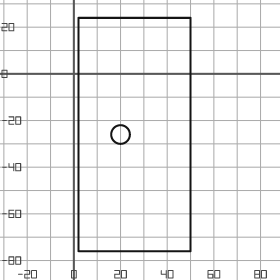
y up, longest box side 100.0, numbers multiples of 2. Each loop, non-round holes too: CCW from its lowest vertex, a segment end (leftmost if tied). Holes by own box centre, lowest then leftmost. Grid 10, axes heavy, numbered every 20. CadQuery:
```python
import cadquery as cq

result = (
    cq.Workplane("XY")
    .moveTo(2.0, -76.0)
    .lineTo(50.0, -76.0)
    .lineTo(50.0, 24.0)
    .lineTo(2.0, 24.0)
    .close()
    .moveTo(20.0, -26.0)
    .circle(4.0)
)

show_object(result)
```